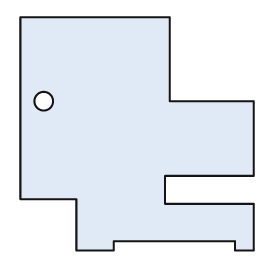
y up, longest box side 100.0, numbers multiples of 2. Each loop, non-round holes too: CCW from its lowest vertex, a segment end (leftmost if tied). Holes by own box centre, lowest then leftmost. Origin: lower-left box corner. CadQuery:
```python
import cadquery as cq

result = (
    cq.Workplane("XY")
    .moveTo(24.0, 0.0)
    .lineTo(40.0, 0.0)
    .lineTo(40.0, 4.0)
    .lineTo(92.0, 4.0)
    .lineTo(92.0, 0.0)
    .lineTo(100.0, 0.0)
    .lineTo(100.0, 20.0)
    .lineTo(62.0, 20.0)
    .lineTo(62.0, 32.0)
    .lineTo(100.0, 32.0)
    .lineTo(100.0, 64.0)
    .lineTo(64.0, 64.0)
    .lineTo(64.0, 100.0)
    .lineTo(0.0, 100.0)
    .lineTo(0.0, 22.0)
    .lineTo(24.0, 22.0)
    .close()
    .moveTo(10.0, 64.0)
    .circle(4.0)
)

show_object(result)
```